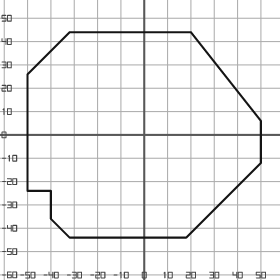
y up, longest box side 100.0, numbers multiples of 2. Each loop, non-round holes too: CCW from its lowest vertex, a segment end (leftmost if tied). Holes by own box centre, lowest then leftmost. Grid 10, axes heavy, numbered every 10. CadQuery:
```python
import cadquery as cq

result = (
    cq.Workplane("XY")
    .moveTo(-32.0, -44.0)
    .lineTo(18.0, -44.0)
    .lineTo(50.0, -12.0)
    .lineTo(50.0, 6.0)
    .lineTo(20.0, 44.0)
    .lineTo(-32.0, 44.0)
    .lineTo(-50.0, 26.0)
    .lineTo(-50.0, -24.0)
    .lineTo(-40.0, -24.0)
    .lineTo(-40.0, -36.0)
    .close()
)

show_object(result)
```